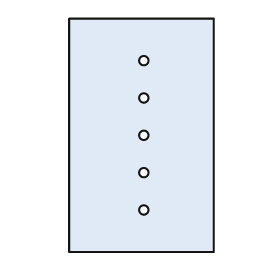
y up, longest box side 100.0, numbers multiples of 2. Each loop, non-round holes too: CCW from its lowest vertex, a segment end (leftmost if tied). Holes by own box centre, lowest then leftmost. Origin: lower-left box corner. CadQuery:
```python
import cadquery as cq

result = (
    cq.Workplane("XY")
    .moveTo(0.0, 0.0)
    .lineTo(62.0, 0.0)
    .lineTo(62.0, 100.0)
    .lineTo(0.0, 100.0)
    .close()
    .moveTo(32.0, 18.0)
    .circle(2.0)
    .moveTo(32.0, 34.0)
    .circle(2.0)
    .moveTo(32.0, 50.0)
    .circle(2.0)
    .moveTo(32.0, 66.0)
    .circle(2.0)
    .moveTo(32.0, 82.0)
    .circle(2.0)
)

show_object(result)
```